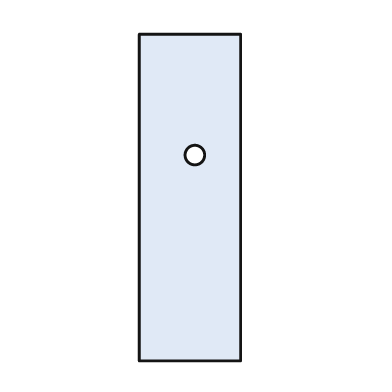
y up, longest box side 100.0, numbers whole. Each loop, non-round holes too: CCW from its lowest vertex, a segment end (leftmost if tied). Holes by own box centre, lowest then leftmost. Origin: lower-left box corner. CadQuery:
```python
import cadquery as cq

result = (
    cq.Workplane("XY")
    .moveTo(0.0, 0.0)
    .lineTo(31.0, 0.0)
    .lineTo(31.0, 100.0)
    .lineTo(0.0, 100.0)
    .close()
    .moveTo(17.0, 63.0)
    .circle(3.0)
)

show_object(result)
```